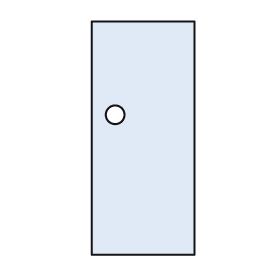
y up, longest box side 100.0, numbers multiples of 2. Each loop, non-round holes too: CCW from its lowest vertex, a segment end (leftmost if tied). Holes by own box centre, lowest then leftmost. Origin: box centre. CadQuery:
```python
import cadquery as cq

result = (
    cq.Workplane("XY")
    .moveTo(-22.0, -50.0)
    .lineTo(22.0, -50.0)
    .lineTo(22.0, 50.0)
    .lineTo(-22.0, 50.0)
    .close()
    .moveTo(-12.0, 10.0)
    .circle(4.0)
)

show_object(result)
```